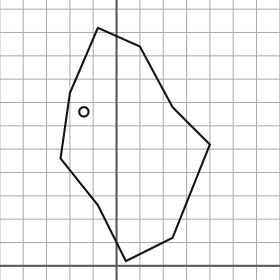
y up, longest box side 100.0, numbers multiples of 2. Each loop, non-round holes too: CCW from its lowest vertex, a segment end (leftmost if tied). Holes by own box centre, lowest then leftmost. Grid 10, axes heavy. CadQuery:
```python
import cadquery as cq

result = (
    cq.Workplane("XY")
    .moveTo(4.0, 2.0)
    .lineTo(24.0, 12.0)
    .lineTo(40.0, 52.0)
    .lineTo(24.0, 68.0)
    .lineTo(10.0, 94.0)
    .lineTo(-8.0, 102.0)
    .lineTo(-20.0, 74.0)
    .lineTo(-24.0, 46.0)
    .lineTo(-8.0, 26.0)
    .close()
    .moveTo(-14.0, 66.0)
    .circle(2.0)
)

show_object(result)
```